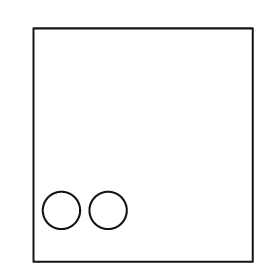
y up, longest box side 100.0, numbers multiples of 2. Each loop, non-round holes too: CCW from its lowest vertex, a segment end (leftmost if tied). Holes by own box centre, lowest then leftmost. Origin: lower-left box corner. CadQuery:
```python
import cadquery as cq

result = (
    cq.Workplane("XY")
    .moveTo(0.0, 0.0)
    .lineTo(94.0, 0.0)
    .lineTo(94.0, 100.0)
    .lineTo(0.0, 100.0)
    .close()
    .moveTo(12.0, 22.0)
    .circle(8.0)
    .moveTo(32.0, 22.0)
    .circle(8.0)
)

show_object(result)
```